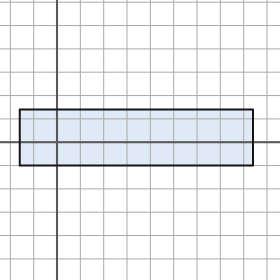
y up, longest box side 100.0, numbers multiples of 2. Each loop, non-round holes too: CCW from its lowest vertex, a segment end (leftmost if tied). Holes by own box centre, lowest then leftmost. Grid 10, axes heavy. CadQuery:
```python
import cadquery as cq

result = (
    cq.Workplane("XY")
    .moveTo(-16.0, -10.0)
    .lineTo(84.0, -10.0)
    .lineTo(84.0, 14.0)
    .lineTo(-16.0, 14.0)
    .close()
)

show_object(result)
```